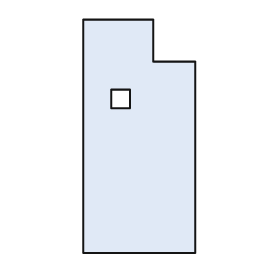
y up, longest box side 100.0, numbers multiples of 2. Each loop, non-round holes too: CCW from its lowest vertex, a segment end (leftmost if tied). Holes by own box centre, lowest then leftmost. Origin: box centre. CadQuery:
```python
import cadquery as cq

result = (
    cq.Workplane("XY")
    .moveTo(-24.0, -50.0)
    .lineTo(24.0, -50.0)
    .lineTo(24.0, 32.0)
    .lineTo(6.0, 32.0)
    .lineTo(6.0, 50.0)
    .lineTo(-24.0, 50.0)
    .close()
    .moveTo(-12.0, 12.0)
    .lineTo(-4.0, 12.0)
    .lineTo(-4.0, 20.0)
    .lineTo(-12.0, 20.0)
    .close()
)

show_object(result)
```